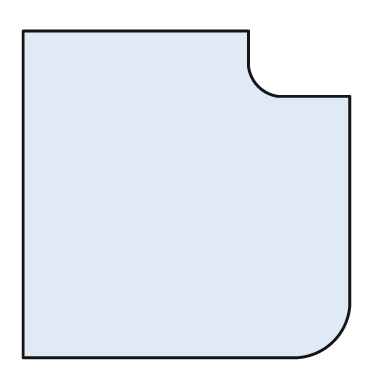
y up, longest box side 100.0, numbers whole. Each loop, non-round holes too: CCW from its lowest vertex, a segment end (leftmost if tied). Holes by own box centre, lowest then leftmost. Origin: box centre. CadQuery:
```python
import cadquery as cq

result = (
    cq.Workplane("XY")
    .moveTo(-50.0, -50.0)
    .lineTo(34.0, -50.0)
    .threePointArc((45.0, -45.0), (50.0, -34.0))
    .lineTo(50.0, 30.0)
    .lineTo(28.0, 30.0)
    .threePointArc((22.0, 33.0), (19.0, 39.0))
    .lineTo(19.0, 50.0)
    .lineTo(-50.0, 50.0)
    .close()
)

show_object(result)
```